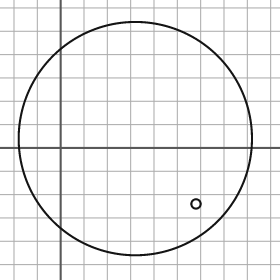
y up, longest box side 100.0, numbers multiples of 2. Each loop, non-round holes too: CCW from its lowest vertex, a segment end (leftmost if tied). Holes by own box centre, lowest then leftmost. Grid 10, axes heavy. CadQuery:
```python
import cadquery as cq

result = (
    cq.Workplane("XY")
    .moveTo(32.0, 4.0)
    .circle(50.0)
    .moveTo(58.0, -24.0)
    .circle(2.0)
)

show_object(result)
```